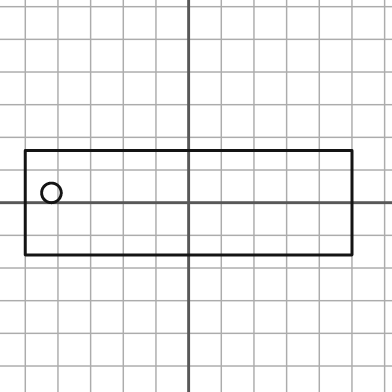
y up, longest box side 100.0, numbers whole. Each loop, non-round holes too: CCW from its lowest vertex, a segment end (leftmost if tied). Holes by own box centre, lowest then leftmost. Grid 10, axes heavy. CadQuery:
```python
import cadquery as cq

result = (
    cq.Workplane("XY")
    .moveTo(-50.0, -16.0)
    .lineTo(50.0, -16.0)
    .lineTo(50.0, 16.0)
    .lineTo(-50.0, 16.0)
    .close()
    .moveTo(-42.0, 3.0)
    .circle(3.0)
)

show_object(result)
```